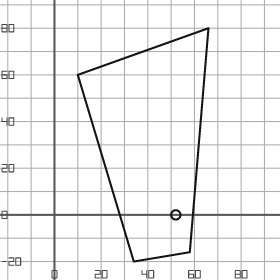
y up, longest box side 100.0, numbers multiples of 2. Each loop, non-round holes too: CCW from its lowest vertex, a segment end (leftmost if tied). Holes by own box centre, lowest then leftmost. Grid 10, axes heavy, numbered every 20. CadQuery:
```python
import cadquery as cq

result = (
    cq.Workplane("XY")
    .moveTo(34.0, -20.0)
    .lineTo(58.0, -16.0)
    .lineTo(66.0, 80.0)
    .lineTo(10.0, 60.0)
    .close()
    .moveTo(52.0, 0.0)
    .circle(2.0)
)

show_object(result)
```